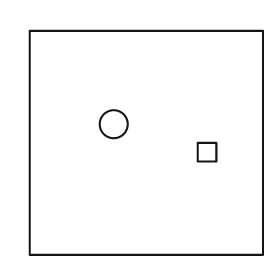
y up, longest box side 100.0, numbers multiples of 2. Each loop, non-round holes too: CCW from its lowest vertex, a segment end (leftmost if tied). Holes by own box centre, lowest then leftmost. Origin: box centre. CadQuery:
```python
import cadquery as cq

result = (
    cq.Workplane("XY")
    .moveTo(-50.0, -48.0)
    .lineTo(50.0, -48.0)
    .lineTo(50.0, 48.0)
    .lineTo(-50.0, 48.0)
    .close()
    .moveTo(22.0, -8.0)
    .lineTo(30.0, -8.0)
    .lineTo(30.0, 0.0)
    .lineTo(22.0, 0.0)
    .close()
    .moveTo(-14.0, 8.0)
    .circle(6.0)
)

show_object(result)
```